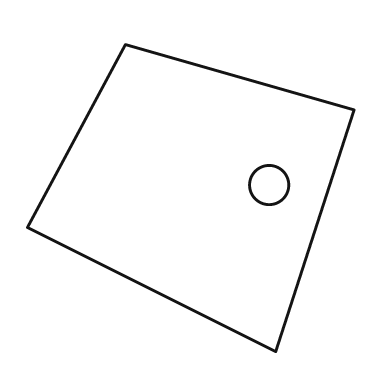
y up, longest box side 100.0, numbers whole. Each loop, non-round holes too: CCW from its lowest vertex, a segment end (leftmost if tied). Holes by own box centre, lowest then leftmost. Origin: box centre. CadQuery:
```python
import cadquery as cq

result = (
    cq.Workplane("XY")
    .moveTo(26.0, -47.0)
    .lineTo(50.0, 27.0)
    .lineTo(-20.0, 47.0)
    .lineTo(-50.0, -9.0)
    .close()
    .moveTo(24.0, 4.0)
    .circle(6.0)
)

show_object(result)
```